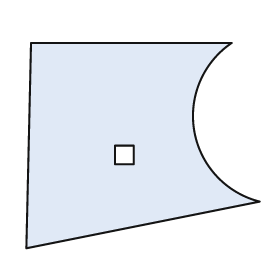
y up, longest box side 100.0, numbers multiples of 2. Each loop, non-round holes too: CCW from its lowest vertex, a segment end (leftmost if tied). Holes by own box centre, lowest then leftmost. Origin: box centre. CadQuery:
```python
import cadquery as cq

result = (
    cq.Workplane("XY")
    .moveTo(-50.0, -44.0)
    .lineTo(50.0, -24.0)
    .threePointArc((22.0, 6.0), (38.0, 44.0))
    .lineTo(-48.0, 44.0)
    .close()
    .moveTo(-12.0, -8.0)
    .lineTo(-4.0, -8.0)
    .lineTo(-4.0, 0.0)
    .lineTo(-12.0, 0.0)
    .close()
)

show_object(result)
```